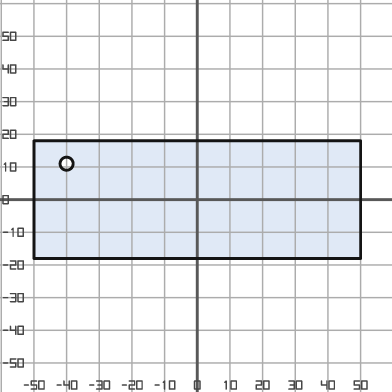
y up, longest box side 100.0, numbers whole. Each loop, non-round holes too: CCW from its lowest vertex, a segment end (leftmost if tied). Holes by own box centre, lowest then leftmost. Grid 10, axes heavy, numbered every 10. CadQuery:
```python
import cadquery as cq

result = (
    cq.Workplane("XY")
    .moveTo(-50.0, -18.0)
    .lineTo(50.0, -18.0)
    .lineTo(50.0, 18.0)
    .lineTo(-50.0, 18.0)
    .close()
    .moveTo(-40.0, 11.0)
    .circle(2.0)
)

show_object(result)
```